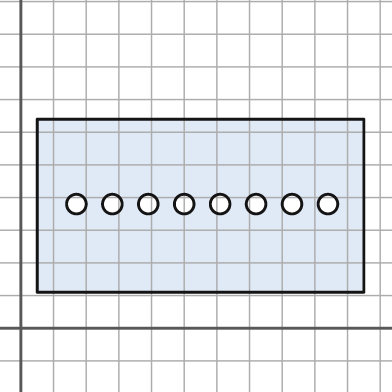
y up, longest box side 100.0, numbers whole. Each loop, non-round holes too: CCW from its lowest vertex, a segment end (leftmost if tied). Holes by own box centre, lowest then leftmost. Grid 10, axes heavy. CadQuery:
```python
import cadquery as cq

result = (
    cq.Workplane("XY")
    .moveTo(5.0, 11.0)
    .lineTo(105.0, 11.0)
    .lineTo(105.0, 64.0)
    .lineTo(5.0, 64.0)
    .close()
    .moveTo(17.0, 38.0)
    .circle(3.0)
    .moveTo(28.0, 38.0)
    .circle(3.0)
    .moveTo(39.0, 38.0)
    .circle(3.0)
    .moveTo(50.0, 38.0)
    .circle(3.0)
    .moveTo(61.0, 38.0)
    .circle(3.0)
    .moveTo(72.0, 38.0)
    .circle(3.0)
    .moveTo(83.0, 38.0)
    .circle(3.0)
    .moveTo(94.0, 38.0)
    .circle(3.0)
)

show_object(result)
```